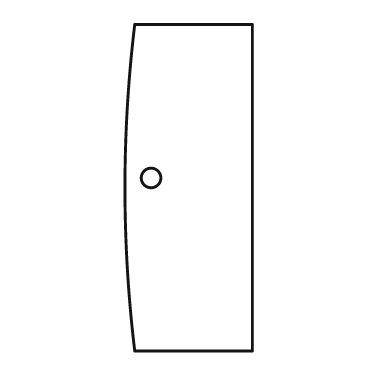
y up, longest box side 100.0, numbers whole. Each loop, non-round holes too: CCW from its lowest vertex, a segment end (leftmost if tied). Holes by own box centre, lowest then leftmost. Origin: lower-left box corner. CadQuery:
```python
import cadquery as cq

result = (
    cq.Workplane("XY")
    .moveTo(3.0, 0.0)
    .lineTo(39.0, 0.0)
    .lineTo(39.0, 100.0)
    .lineTo(3.0, 100.0)
    .threePointArc((0.0, 50.0), (3.0, 0.0))
    .close()
    .moveTo(8.0, 53.0)
    .circle(3.0)
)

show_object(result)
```